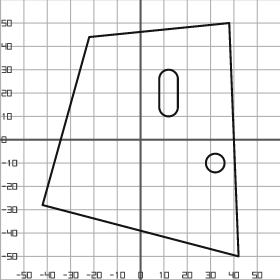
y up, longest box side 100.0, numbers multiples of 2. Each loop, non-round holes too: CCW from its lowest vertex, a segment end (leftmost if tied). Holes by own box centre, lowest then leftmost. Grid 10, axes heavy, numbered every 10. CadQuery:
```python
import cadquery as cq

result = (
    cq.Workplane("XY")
    .moveTo(42.0, -50.0)
    .lineTo(38.0, 50.0)
    .lineTo(-22.0, 44.0)
    .lineTo(-42.0, -28.0)
    .close()
    .moveTo(32.0, -10.0)
    .circle(4.0)
    .moveTo(8.0, 14.0)
    .threePointArc((12.0, 10.0), (16.0, 14.0))
    .lineTo(16.0, 26.0)
    .threePointArc((12.0, 30.0), (8.0, 26.0))
    .close()
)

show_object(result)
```